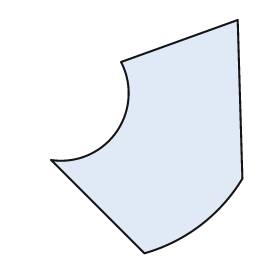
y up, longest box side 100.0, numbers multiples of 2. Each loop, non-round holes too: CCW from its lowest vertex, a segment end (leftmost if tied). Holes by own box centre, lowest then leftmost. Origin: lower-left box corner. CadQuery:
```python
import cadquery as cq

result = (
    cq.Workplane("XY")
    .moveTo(40.0, 0.0)
    .threePointArc((64.0, 12.0), (82.0, 32.0))
    .lineTo(80.0, 100.0)
    .lineTo(30.0, 82.0)
    .threePointArc((28.0, 52.0), (0.0, 40.0))
    .close()
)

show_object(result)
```